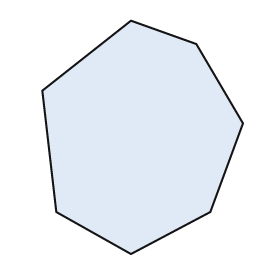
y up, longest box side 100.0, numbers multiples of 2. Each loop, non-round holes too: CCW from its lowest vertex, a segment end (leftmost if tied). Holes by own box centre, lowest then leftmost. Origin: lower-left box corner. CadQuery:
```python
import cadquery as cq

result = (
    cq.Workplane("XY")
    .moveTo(38.0, 0.0)
    .lineTo(72.0, 18.0)
    .lineTo(86.0, 56.0)
    .lineTo(66.0, 90.0)
    .lineTo(38.0, 100.0)
    .lineTo(0.0, 70.0)
    .lineTo(6.0, 18.0)
    .close()
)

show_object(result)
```